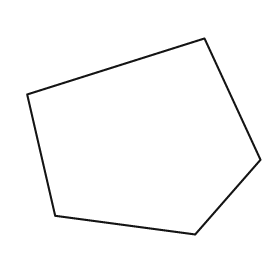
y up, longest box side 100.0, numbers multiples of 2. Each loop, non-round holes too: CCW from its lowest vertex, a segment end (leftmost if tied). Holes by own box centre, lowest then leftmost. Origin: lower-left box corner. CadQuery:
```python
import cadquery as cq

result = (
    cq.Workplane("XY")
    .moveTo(72.0, 0.0)
    .lineTo(100.0, 32.0)
    .lineTo(76.0, 84.0)
    .lineTo(0.0, 60.0)
    .lineTo(12.0, 8.0)
    .close()
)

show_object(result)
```